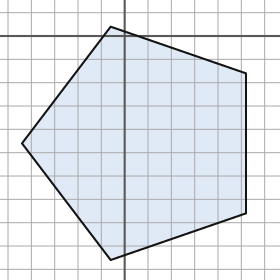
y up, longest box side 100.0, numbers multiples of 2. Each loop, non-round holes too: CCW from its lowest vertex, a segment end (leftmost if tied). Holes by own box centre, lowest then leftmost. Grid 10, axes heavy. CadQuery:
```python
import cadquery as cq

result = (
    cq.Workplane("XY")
    .moveTo(-6.0, -96.0)
    .lineTo(52.0, -76.0)
    .lineTo(52.0, -16.0)
    .lineTo(-6.0, 4.0)
    .lineTo(-44.0, -46.0)
    .close()
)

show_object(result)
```